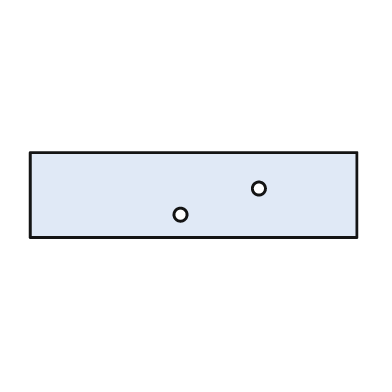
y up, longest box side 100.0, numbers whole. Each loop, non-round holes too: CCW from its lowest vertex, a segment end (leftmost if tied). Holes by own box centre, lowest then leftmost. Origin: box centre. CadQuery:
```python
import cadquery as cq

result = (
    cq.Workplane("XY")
    .moveTo(-50.0, -13.0)
    .lineTo(50.0, -13.0)
    .lineTo(50.0, 13.0)
    .lineTo(-50.0, 13.0)
    .close()
    .moveTo(-4.0, -6.0)
    .circle(2.0)
    .moveTo(20.0, 2.0)
    .circle(2.0)
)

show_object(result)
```